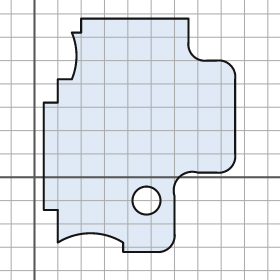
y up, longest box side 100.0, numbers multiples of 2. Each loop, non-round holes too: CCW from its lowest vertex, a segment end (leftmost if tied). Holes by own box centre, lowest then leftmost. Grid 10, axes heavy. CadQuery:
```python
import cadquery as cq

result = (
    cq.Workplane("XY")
    .moveTo(38.0, -32.0)
    .lineTo(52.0, -32.0)
    .threePointArc((58.0, -30.0), (60.0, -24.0))
    .lineTo(60.0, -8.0)
    .threePointArc((62.0, 0.0), (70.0, 2.0))
    .lineTo(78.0, 2.0)
    .threePointArc((84.0, 4.0), (86.0, 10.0))
    .lineTo(86.0, 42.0)
    .threePointArc((84.0, 48.0), (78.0, 50.0))
    .lineTo(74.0, 50.0)
    .threePointArc((68.0, 52.0), (66.0, 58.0))
    .lineTo(66.0, 68.0)
    .lineTo(20.0, 68.0)
    .lineTo(20.0, 62.0)
    .lineTo(16.0, 62.0)
    .threePointArc((18.0, 52.0), (16.0, 42.0))
    .lineTo(10.0, 42.0)
    .lineTo(10.0, 32.0)
    .lineTo(4.0, 32.0)
    .lineTo(4.0, -14.0)
    .lineTo(10.0, -14.0)
    .lineTo(10.0, -28.0)
    .threePointArc((24.0, -24.0), (38.0, -28.0))
    .close()
    .moveTo(48.0, -10.0)
    .circle(6.0)
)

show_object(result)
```